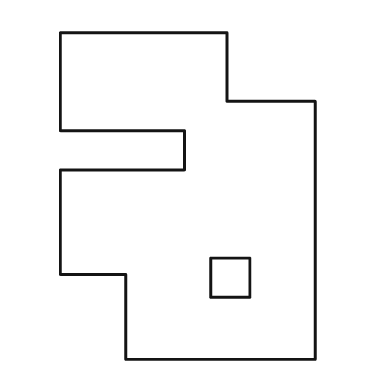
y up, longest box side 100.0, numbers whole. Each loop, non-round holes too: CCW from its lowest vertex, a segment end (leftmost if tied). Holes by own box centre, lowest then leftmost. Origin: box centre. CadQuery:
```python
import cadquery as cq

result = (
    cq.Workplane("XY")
    .moveTo(-19.0, -50.0)
    .lineTo(39.0, -50.0)
    .lineTo(39.0, 29.0)
    .lineTo(12.0, 29.0)
    .lineTo(12.0, 50.0)
    .lineTo(-39.0, 50.0)
    .lineTo(-39.0, 20.0)
    .lineTo(-1.0, 20.0)
    .lineTo(-1.0, 8.0)
    .lineTo(-39.0, 8.0)
    .lineTo(-39.0, -24.0)
    .lineTo(-19.0, -24.0)
    .close()
    .moveTo(7.0, -31.0)
    .lineTo(19.0, -31.0)
    .lineTo(19.0, -19.0)
    .lineTo(7.0, -19.0)
    .close()
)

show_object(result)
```